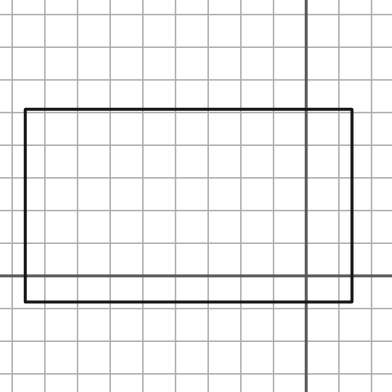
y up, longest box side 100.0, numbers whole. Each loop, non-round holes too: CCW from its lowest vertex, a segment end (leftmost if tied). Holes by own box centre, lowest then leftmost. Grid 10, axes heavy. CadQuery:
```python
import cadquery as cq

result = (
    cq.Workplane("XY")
    .moveTo(-86.0, -8.0)
    .lineTo(14.0, -8.0)
    .lineTo(14.0, 51.0)
    .lineTo(-86.0, 51.0)
    .close()
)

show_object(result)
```